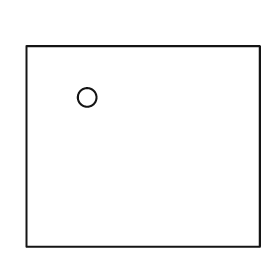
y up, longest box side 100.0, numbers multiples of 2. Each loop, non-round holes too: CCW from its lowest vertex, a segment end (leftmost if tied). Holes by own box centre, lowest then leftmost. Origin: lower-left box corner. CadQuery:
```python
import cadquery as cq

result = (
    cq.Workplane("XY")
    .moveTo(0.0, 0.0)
    .lineTo(100.0, 0.0)
    .lineTo(100.0, 86.0)
    .lineTo(0.0, 86.0)
    .close()
    .moveTo(26.0, 64.0)
    .circle(4.0)
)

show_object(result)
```